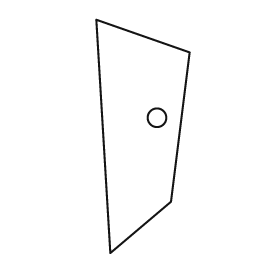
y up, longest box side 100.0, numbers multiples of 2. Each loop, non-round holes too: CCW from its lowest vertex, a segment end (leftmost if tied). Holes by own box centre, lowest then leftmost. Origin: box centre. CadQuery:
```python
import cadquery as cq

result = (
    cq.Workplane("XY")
    .moveTo(-14.0, -50.0)
    .lineTo(12.0, -28.0)
    .lineTo(20.0, 36.0)
    .lineTo(-20.0, 50.0)
    .close()
    .moveTo(6.0, 8.0)
    .circle(4.0)
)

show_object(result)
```